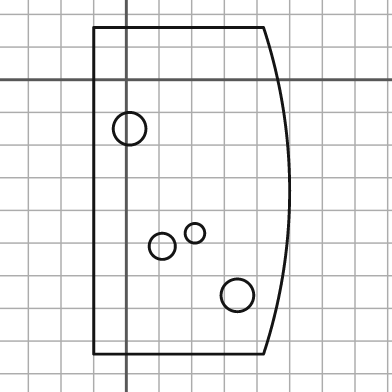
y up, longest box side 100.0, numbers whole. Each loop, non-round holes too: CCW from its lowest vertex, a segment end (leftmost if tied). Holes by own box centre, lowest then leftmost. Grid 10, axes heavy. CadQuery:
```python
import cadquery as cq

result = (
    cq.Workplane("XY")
    .moveTo(-10.0, -84.0)
    .lineTo(42.0, -84.0)
    .threePointArc((50.0, -34.0), (42.0, 16.0))
    .lineTo(-10.0, 16.0)
    .close()
    .moveTo(34.0, -66.0)
    .circle(5.0)
    .moveTo(11.0, -51.0)
    .circle(4.0)
    .moveTo(21.0, -47.0)
    .circle(3.0)
    .moveTo(1.0, -15.0)
    .circle(5.0)
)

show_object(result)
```